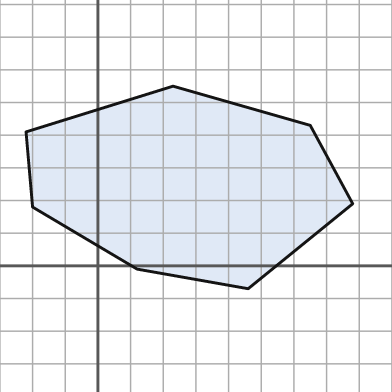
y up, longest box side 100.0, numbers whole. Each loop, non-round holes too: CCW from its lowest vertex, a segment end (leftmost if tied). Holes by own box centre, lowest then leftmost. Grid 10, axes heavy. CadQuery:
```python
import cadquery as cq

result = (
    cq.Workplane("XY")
    .moveTo(46.0, -7.0)
    .lineTo(78.0, 19.0)
    .lineTo(65.0, 43.0)
    .lineTo(23.0, 55.0)
    .lineTo(-22.0, 41.0)
    .lineTo(-20.0, 18.0)
    .lineTo(12.0, -1.0)
    .close()
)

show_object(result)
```